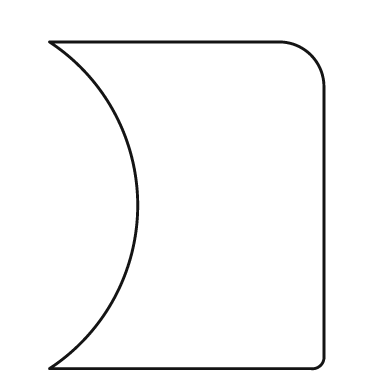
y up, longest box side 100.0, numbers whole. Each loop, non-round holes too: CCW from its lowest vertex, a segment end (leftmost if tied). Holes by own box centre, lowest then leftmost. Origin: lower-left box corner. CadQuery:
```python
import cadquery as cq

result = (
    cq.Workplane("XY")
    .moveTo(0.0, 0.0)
    .lineTo(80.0, 0.0)
    .threePointArc((83.0, 1.0), (84.0, 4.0))
    .lineTo(84.0, 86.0)
    .threePointArc((80.0, 96.0), (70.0, 100.0))
    .lineTo(0.0, 100.0)
    .threePointArc((27.0, 50.0), (0.0, 0.0))
    .close()
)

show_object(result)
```